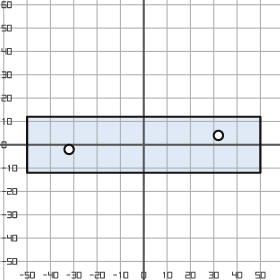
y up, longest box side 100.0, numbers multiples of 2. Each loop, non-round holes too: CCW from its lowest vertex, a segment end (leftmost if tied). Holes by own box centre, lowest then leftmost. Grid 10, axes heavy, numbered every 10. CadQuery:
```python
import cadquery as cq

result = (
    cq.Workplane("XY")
    .moveTo(-50.0, -12.0)
    .lineTo(50.0, -12.0)
    .lineTo(50.0, 12.0)
    .lineTo(-50.0, 12.0)
    .close()
    .moveTo(-32.0, -2.0)
    .circle(2.0)
    .moveTo(32.0, 4.0)
    .circle(2.0)
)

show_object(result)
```